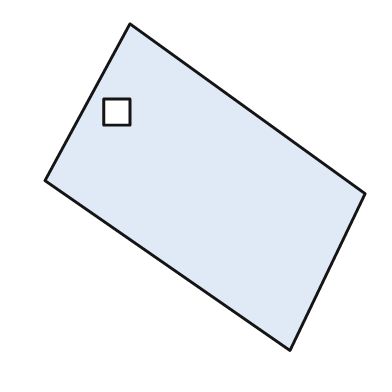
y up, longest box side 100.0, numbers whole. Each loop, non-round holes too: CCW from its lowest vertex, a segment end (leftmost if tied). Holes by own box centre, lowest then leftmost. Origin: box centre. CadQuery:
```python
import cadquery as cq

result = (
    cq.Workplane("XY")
    .moveTo(26.0, -50.0)
    .lineTo(49.0, -2.0)
    .lineTo(-23.0, 50.0)
    .lineTo(-49.0, 2.0)
    .close()
    .moveTo(-31.0, 19.0)
    .lineTo(-23.0, 19.0)
    .lineTo(-23.0, 27.0)
    .lineTo(-31.0, 27.0)
    .close()
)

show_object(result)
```